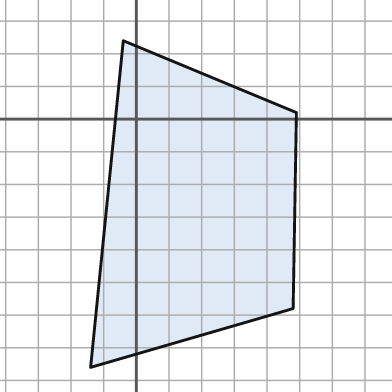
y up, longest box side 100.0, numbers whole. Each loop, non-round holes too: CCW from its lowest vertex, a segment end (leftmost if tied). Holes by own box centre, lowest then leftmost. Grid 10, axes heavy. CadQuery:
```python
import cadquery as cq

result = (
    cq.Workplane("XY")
    .moveTo(-14.0, -76.0)
    .lineTo(48.0, -58.0)
    .lineTo(49.0, 2.0)
    .lineTo(-4.0, 24.0)
    .close()
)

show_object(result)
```